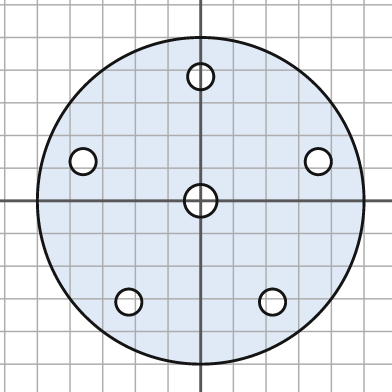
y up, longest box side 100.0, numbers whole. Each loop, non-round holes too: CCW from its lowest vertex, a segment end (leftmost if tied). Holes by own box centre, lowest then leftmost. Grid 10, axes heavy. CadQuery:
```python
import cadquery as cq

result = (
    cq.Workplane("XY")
    .moveTo(0.0, 0.0)
    .circle(50.0)
    .moveTo(-22.0, -31.0)
    .circle(4.0)
    .moveTo(22.0, -31.0)
    .circle(4.0)
    .moveTo(0.0, 0.0)
    .circle(5.0)
    .moveTo(-36.0, 12.0)
    .circle(4.0)
    .moveTo(36.0, 12.0)
    .circle(4.0)
    .moveTo(0.0, 38.0)
    .circle(4.0)
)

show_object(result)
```